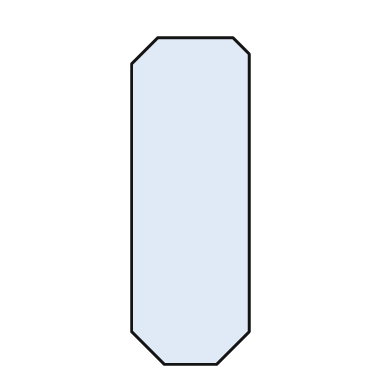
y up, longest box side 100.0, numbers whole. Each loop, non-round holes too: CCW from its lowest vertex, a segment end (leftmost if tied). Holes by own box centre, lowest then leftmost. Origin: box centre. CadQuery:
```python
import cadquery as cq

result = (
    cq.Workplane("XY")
    .moveTo(-8.0, -50.0)
    .lineTo(8.0, -50.0)
    .lineTo(18.0, -40.0)
    .lineTo(18.0, 45.0)
    .lineTo(13.0, 50.0)
    .lineTo(-10.0, 50.0)
    .lineTo(-18.0, 42.0)
    .lineTo(-18.0, -40.0)
    .close()
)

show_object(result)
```